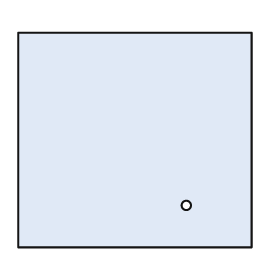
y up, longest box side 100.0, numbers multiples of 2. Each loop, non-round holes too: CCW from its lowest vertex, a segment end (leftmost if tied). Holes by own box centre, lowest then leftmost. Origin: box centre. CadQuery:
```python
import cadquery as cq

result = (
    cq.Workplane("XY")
    .moveTo(-50.0, -46.0)
    .lineTo(50.0, -46.0)
    .lineTo(50.0, 46.0)
    .lineTo(-50.0, 46.0)
    .close()
    .moveTo(22.0, -28.0)
    .circle(2.0)
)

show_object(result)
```